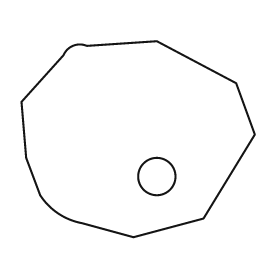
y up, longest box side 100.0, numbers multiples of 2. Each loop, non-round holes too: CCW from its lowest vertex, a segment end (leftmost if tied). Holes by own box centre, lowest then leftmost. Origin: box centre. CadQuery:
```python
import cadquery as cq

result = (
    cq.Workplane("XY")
    .moveTo(-2.0, -42.0)
    .lineTo(28.0, -34.0)
    .lineTo(50.0, 2.0)
    .lineTo(42.0, 24.0)
    .lineTo(8.0, 42.0)
    .lineTo(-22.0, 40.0)
    .threePointArc((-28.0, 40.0), (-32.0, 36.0))
    .lineTo(-50.0, 16.0)
    .lineTo(-48.0, -8.0)
    .lineTo(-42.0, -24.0)
    .threePointArc((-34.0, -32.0), (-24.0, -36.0))
    .close()
    .moveTo(8.0, -16.0)
    .circle(8.0)
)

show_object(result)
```